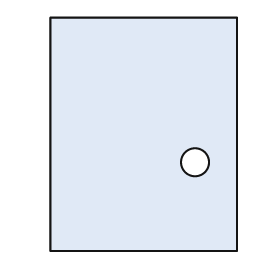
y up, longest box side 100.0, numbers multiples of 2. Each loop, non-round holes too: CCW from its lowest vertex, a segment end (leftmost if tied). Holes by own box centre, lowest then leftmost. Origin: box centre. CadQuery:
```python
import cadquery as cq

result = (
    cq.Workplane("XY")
    .moveTo(-40.0, -50.0)
    .lineTo(40.0, -50.0)
    .lineTo(40.0, 50.0)
    .lineTo(-40.0, 50.0)
    .close()
    .moveTo(22.0, -12.0)
    .circle(6.0)
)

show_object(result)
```